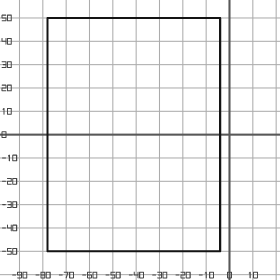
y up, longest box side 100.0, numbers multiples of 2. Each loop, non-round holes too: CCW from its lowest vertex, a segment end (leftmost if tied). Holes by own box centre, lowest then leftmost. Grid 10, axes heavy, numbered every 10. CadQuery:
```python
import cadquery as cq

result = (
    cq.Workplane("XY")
    .moveTo(-78.0, -50.0)
    .lineTo(-4.0, -50.0)
    .lineTo(-4.0, 50.0)
    .lineTo(-78.0, 50.0)
    .close()
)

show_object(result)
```